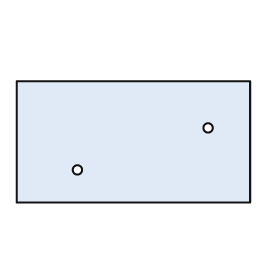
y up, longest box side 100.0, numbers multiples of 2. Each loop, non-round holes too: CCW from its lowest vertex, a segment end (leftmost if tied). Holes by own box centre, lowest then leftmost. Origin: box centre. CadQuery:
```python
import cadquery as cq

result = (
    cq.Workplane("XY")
    .moveTo(-50.0, -26.0)
    .lineTo(50.0, -26.0)
    .lineTo(50.0, 26.0)
    .lineTo(-50.0, 26.0)
    .close()
    .moveTo(-24.0, -12.0)
    .circle(2.0)
    .moveTo(32.0, 6.0)
    .circle(2.0)
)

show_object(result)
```